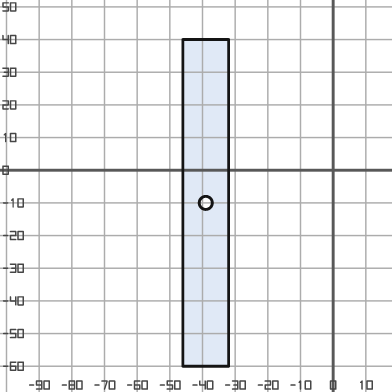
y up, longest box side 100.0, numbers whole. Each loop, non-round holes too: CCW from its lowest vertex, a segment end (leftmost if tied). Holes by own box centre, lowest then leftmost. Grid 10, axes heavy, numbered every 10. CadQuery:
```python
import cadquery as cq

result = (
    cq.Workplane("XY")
    .moveTo(-46.0, -60.0)
    .lineTo(-32.0, -60.0)
    .lineTo(-32.0, 40.0)
    .lineTo(-46.0, 40.0)
    .close()
    .moveTo(-39.0, -10.0)
    .circle(2.0)
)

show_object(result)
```